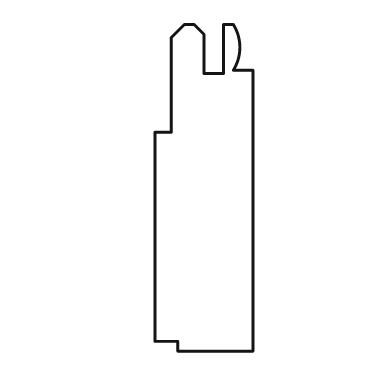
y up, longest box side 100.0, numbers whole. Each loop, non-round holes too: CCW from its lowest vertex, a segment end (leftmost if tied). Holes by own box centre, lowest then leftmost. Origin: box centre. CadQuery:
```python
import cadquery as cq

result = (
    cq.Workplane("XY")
    .moveTo(-8.0, -50.0)
    .lineTo(15.0, -50.0)
    .lineTo(15.0, 36.0)
    .lineTo(9.0, 36.0)
    .threePointArc((11.0, 43.0), (9.0, 50.0))
    .lineTo(6.0, 50.0)
    .lineTo(6.0, 35.0)
    .lineTo(0.0, 35.0)
    .lineTo(0.0, 47.0)
    .lineTo(-3.0, 50.0)
    .lineTo(-6.0, 50.0)
    .lineTo(-10.0, 46.0)
    .lineTo(-10.0, 17.0)
    .lineTo(-15.0, 17.0)
    .lineTo(-15.0, -47.0)
    .lineTo(-8.0, -47.0)
    .close()
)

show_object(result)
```